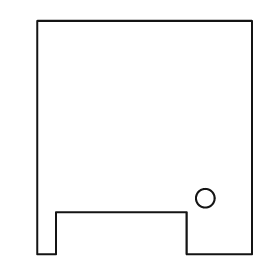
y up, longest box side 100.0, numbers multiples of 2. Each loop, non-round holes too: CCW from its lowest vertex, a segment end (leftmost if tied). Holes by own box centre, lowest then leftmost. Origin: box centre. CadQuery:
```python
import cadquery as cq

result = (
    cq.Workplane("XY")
    .moveTo(-46.0, -50.0)
    .lineTo(-38.0, -50.0)
    .lineTo(-38.0, -32.0)
    .lineTo(18.0, -32.0)
    .lineTo(18.0, -50.0)
    .lineTo(46.0, -50.0)
    .lineTo(46.0, 50.0)
    .lineTo(-46.0, 50.0)
    .close()
    .moveTo(26.0, -26.0)
    .circle(4.0)
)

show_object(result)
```